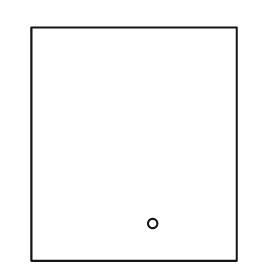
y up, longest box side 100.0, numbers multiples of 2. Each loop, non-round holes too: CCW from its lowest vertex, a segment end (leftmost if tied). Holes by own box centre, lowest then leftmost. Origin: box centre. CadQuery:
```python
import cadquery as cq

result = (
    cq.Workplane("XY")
    .moveTo(-44.0, -50.0)
    .lineTo(44.0, -50.0)
    .lineTo(44.0, 50.0)
    .lineTo(-44.0, 50.0)
    .close()
    .moveTo(8.0, -34.0)
    .circle(2.0)
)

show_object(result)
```